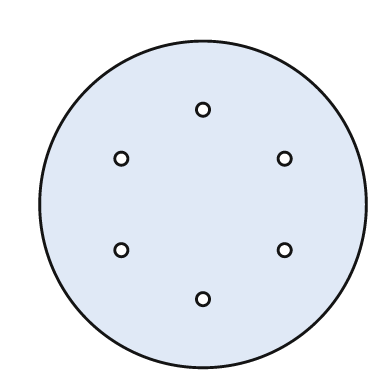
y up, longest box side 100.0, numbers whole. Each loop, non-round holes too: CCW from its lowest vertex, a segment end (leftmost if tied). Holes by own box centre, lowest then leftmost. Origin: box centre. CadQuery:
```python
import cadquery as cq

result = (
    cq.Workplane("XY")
    .moveTo(0.0, 0.0)
    .circle(50.0)
    .moveTo(0.0, -29.0)
    .circle(2.0)
    .moveTo(-25.0, -14.0)
    .circle(2.0)
    .moveTo(25.0, -14.0)
    .circle(2.0)
    .moveTo(-25.0, 14.0)
    .circle(2.0)
    .moveTo(25.0, 14.0)
    .circle(2.0)
    .moveTo(0.0, 29.0)
    .circle(2.0)
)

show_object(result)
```